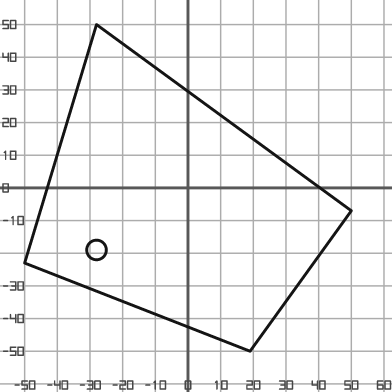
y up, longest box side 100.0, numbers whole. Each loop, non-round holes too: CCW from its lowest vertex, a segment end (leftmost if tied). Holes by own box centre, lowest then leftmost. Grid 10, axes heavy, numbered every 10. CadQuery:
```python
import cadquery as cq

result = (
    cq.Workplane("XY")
    .moveTo(19.0, -50.0)
    .lineTo(50.0, -7.0)
    .lineTo(-28.0, 50.0)
    .lineTo(-50.0, -23.0)
    .close()
    .moveTo(-28.0, -19.0)
    .circle(3.0)
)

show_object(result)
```